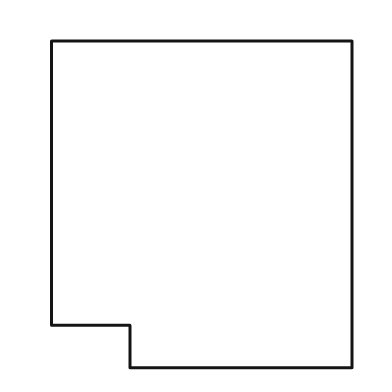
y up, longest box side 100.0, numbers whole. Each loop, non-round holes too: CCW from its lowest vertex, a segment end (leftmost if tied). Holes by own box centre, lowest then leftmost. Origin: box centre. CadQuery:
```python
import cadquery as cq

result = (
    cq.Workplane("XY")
    .moveTo(-22.0, -50.0)
    .lineTo(46.0, -50.0)
    .lineTo(46.0, 50.0)
    .lineTo(-46.0, 50.0)
    .lineTo(-46.0, -37.0)
    .lineTo(-22.0, -37.0)
    .close()
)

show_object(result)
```